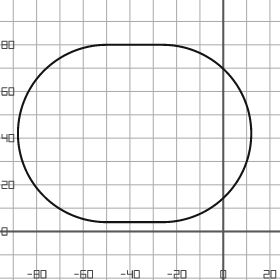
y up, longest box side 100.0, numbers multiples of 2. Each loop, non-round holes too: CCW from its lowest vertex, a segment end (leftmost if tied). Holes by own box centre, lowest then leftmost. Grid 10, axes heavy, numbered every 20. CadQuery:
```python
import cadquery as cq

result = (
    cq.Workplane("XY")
    .moveTo(-50.0, 4.0)
    .lineTo(-26.0, 4.0)
    .threePointArc((12.0, 42.0), (-26.0, 80.0))
    .lineTo(-50.0, 80.0)
    .threePointArc((-88.0, 42.0), (-50.0, 4.0))
    .close()
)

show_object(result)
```